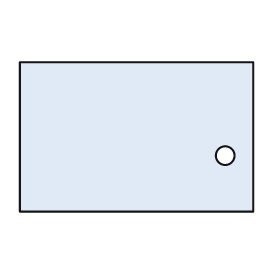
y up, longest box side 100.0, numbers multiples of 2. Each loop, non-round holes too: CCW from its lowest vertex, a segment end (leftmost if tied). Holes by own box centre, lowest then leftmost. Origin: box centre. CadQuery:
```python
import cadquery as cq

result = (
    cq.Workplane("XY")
    .moveTo(-50.0, -32.0)
    .lineTo(50.0, -32.0)
    .lineTo(50.0, 32.0)
    .lineTo(-50.0, 32.0)
    .close()
    .moveTo(38.0, -8.0)
    .circle(4.0)
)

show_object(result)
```